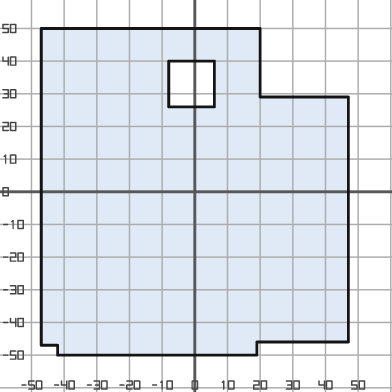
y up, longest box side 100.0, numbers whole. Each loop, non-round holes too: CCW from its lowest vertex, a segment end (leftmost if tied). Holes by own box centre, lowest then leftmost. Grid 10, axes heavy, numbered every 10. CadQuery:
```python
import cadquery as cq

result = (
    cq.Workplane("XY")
    .moveTo(-42.0, -50.0)
    .lineTo(19.0, -50.0)
    .lineTo(19.0, -46.0)
    .lineTo(47.0, -46.0)
    .lineTo(47.0, 29.0)
    .lineTo(20.0, 29.0)
    .lineTo(20.0, 50.0)
    .lineTo(-47.0, 50.0)
    .lineTo(-47.0, -47.0)
    .lineTo(-42.0, -47.0)
    .close()
    .moveTo(-8.0, 26.0)
    .lineTo(6.0, 26.0)
    .lineTo(6.0, 40.0)
    .lineTo(-8.0, 40.0)
    .close()
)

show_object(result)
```